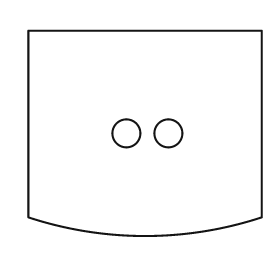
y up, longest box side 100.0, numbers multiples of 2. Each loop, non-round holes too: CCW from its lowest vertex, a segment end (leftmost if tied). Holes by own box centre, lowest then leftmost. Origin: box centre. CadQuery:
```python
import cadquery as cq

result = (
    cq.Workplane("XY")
    .moveTo(-50.0, -36.0)
    .threePointArc((0.0, -44.0), (50.0, -36.0))
    .lineTo(50.0, 44.0)
    .lineTo(-50.0, 44.0)
    .close()
    .moveTo(-8.0, 0.0)
    .circle(6.0)
    .moveTo(10.0, 0.0)
    .circle(6.0)
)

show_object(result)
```